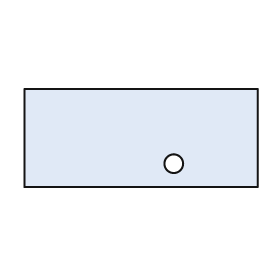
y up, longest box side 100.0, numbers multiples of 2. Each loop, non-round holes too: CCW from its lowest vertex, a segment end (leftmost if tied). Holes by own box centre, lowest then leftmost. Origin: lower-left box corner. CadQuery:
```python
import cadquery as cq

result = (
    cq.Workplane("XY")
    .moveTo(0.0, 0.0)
    .lineTo(100.0, 0.0)
    .lineTo(100.0, 42.0)
    .lineTo(0.0, 42.0)
    .close()
    .moveTo(64.0, 10.0)
    .circle(4.0)
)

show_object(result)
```